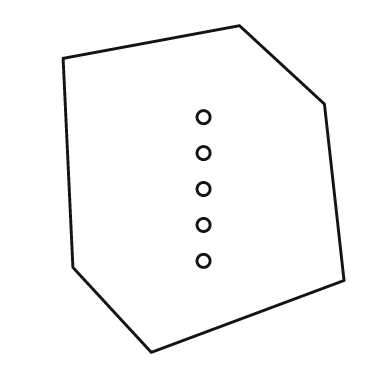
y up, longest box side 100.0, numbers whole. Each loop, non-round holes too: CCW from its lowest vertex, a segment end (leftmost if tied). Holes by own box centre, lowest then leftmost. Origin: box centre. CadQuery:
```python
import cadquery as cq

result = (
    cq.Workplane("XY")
    .moveTo(-16.0, -50.0)
    .lineTo(43.0, -28.0)
    .lineTo(37.0, 26.0)
    .lineTo(11.0, 50.0)
    .lineTo(-43.0, 40.0)
    .lineTo(-40.0, -24.0)
    .close()
    .moveTo(0.0, -22.0)
    .circle(2.0)
    .moveTo(0.0, -11.0)
    .circle(2.0)
    .moveTo(0.0, 0.0)
    .circle(2.0)
    .moveTo(0.0, 11.0)
    .circle(2.0)
    .moveTo(0.0, 22.0)
    .circle(2.0)
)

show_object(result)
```